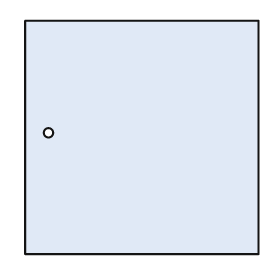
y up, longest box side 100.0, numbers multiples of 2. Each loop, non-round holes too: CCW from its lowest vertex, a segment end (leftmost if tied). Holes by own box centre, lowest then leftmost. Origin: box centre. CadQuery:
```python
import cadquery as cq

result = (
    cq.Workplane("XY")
    .moveTo(-50.0, -50.0)
    .lineTo(50.0, -50.0)
    .lineTo(50.0, 50.0)
    .lineTo(-50.0, 50.0)
    .close()
    .moveTo(-40.0, 2.0)
    .circle(2.0)
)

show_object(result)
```